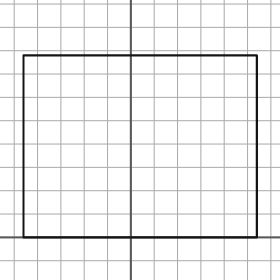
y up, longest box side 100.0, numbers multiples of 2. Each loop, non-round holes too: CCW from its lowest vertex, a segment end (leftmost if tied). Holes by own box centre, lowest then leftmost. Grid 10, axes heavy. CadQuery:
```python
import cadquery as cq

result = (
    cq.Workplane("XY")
    .moveTo(-46.0, 0.0)
    .lineTo(54.0, 0.0)
    .lineTo(54.0, 78.0)
    .lineTo(-46.0, 78.0)
    .close()
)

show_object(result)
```